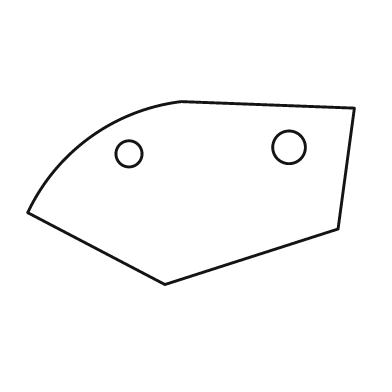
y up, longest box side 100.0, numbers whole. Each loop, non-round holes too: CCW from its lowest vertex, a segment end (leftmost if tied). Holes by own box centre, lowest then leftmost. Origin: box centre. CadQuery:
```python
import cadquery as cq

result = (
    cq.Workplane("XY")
    .moveTo(-8.0, -28.0)
    .lineTo(45.0, -11.0)
    .lineTo(50.0, 26.0)
    .lineTo(-3.0, 28.0)
    .threePointArc((-31.0, 17.0), (-50.0, -6.0))
    .close()
    .moveTo(-19.0, 12.0)
    .circle(4.0)
    .moveTo(30.0, 14.0)
    .circle(5.0)
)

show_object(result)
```